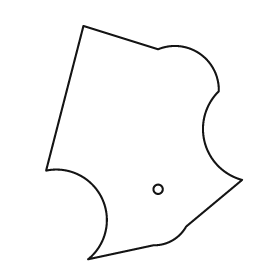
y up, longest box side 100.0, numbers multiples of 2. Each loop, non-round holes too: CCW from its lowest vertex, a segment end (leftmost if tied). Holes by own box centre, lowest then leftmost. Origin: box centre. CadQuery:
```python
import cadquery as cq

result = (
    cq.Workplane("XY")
    .moveTo(-24.0, -50.0)
    .lineTo(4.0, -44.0)
    .threePointArc((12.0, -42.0), (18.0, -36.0))
    .lineTo(42.0, -16.0)
    .threePointArc((26.0, 0.0), (32.0, 22.0))
    .threePointArc((24.0, 38.0), (6.0, 40.0))
    .lineTo(-26.0, 50.0)
    .lineTo(-42.0, -12.0)
    .threePointArc((-18.0, -24.0), (-24.0, -50.0))
    .close()
    .moveTo(6.0, -20.0)
    .circle(2.0)
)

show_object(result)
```